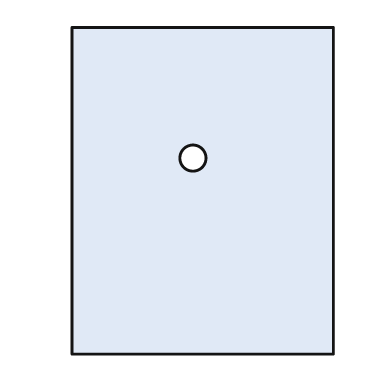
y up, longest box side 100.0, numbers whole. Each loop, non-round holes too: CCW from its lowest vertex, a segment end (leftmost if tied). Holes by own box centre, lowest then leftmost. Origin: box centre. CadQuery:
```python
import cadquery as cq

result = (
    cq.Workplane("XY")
    .moveTo(-40.0, -50.0)
    .lineTo(40.0, -50.0)
    .lineTo(40.0, 50.0)
    .lineTo(-40.0, 50.0)
    .close()
    .moveTo(-3.0, 10.0)
    .circle(4.0)
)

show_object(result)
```